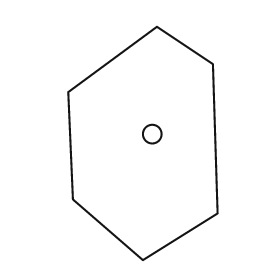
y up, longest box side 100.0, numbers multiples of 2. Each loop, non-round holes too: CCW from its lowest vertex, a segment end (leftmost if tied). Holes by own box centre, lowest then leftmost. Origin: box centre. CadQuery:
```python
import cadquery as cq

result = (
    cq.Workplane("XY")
    .moveTo(0.0, -50.0)
    .lineTo(32.0, -30.0)
    .lineTo(30.0, 34.0)
    .lineTo(6.0, 50.0)
    .lineTo(-32.0, 22.0)
    .lineTo(-30.0, -24.0)
    .close()
    .moveTo(4.0, 4.0)
    .circle(4.0)
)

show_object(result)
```